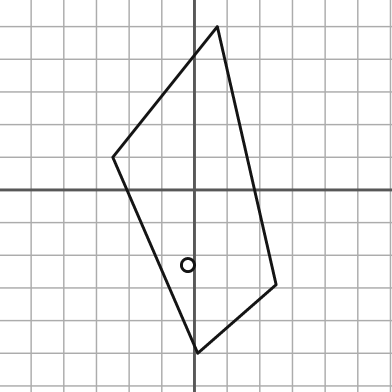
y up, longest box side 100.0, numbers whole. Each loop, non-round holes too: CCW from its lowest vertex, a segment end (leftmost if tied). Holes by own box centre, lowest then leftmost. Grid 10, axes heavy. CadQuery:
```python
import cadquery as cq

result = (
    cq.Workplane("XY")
    .moveTo(1.0, -50.0)
    .lineTo(25.0, -29.0)
    .lineTo(7.0, 50.0)
    .lineTo(-25.0, 10.0)
    .close()
    .moveTo(-2.0, -23.0)
    .circle(2.0)
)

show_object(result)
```